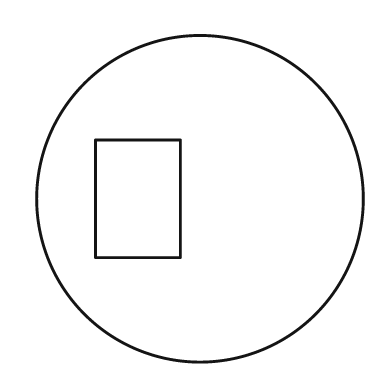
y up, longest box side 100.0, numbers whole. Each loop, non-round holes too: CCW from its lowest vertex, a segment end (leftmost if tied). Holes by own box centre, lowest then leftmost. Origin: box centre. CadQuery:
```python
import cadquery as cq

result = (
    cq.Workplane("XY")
    .moveTo(0.0, 0.0)
    .circle(50.0)
    .moveTo(-32.0, -18.0)
    .lineTo(-6.0, -18.0)
    .lineTo(-6.0, 18.0)
    .lineTo(-32.0, 18.0)
    .close()
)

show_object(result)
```